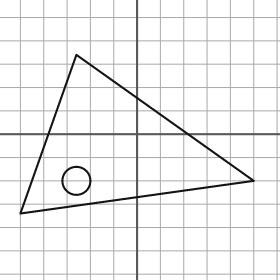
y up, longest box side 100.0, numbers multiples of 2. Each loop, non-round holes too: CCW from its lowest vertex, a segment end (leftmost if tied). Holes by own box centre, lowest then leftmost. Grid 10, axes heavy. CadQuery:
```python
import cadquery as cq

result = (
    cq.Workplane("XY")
    .moveTo(-50.0, -34.0)
    .lineTo(50.0, -20.0)
    .lineTo(-26.0, 34.0)
    .close()
    .moveTo(-26.0, -20.0)
    .circle(6.0)
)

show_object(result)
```